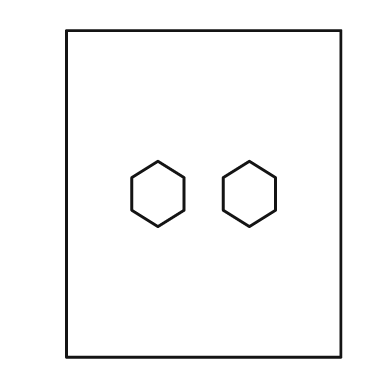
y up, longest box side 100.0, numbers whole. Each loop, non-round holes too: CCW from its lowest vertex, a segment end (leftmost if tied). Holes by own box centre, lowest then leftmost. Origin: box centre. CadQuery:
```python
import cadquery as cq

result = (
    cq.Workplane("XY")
    .moveTo(-42.0, -50.0)
    .lineTo(42.0, -50.0)
    .lineTo(42.0, 50.0)
    .lineTo(-42.0, 50.0)
    .close()
    .moveTo(-14.0, -10.0)
    .lineTo(-6.0, -5.0)
    .lineTo(-6.0, 5.0)
    .lineTo(-14.0, 10.0)
    .lineTo(-22.0, 5.0)
    .lineTo(-22.0, -5.0)
    .close()
    .moveTo(14.0, -10.0)
    .lineTo(22.0, -5.0)
    .lineTo(22.0, 5.0)
    .lineTo(14.0, 10.0)
    .lineTo(6.0, 5.0)
    .lineTo(6.0, -5.0)
    .close()
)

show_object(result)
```